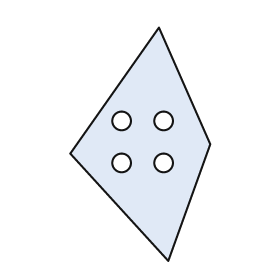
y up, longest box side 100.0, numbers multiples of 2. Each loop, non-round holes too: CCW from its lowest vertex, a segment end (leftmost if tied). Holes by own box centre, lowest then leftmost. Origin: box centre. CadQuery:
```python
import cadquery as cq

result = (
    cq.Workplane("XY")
    .moveTo(12.0, -50.0)
    .lineTo(30.0, 0.0)
    .lineTo(8.0, 50.0)
    .lineTo(-30.0, -4.0)
    .close()
    .moveTo(-8.0, -8.0)
    .circle(4.0)
    .moveTo(10.0, -8.0)
    .circle(4.0)
    .moveTo(-8.0, 10.0)
    .circle(4.0)
    .moveTo(10.0, 10.0)
    .circle(4.0)
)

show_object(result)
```